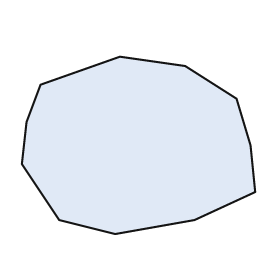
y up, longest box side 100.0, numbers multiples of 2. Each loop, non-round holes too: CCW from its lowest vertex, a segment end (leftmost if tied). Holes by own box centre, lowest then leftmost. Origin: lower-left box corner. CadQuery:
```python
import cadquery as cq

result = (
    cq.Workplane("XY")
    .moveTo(40.0, 0.0)
    .lineTo(74.0, 6.0)
    .lineTo(100.0, 18.0)
    .lineTo(98.0, 38.0)
    .lineTo(92.0, 58.0)
    .lineTo(70.0, 72.0)
    .lineTo(42.0, 76.0)
    .lineTo(8.0, 64.0)
    .lineTo(2.0, 48.0)
    .lineTo(0.0, 30.0)
    .lineTo(16.0, 6.0)
    .close()
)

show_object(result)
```